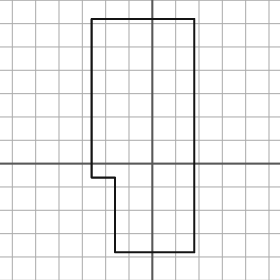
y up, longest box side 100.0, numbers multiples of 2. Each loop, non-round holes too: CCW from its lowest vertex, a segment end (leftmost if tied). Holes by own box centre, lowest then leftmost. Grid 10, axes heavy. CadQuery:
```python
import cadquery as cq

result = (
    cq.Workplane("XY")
    .moveTo(-16.0, -38.0)
    .lineTo(18.0, -38.0)
    .lineTo(18.0, 62.0)
    .lineTo(-26.0, 62.0)
    .lineTo(-26.0, -6.0)
    .lineTo(-16.0, -6.0)
    .close()
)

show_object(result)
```